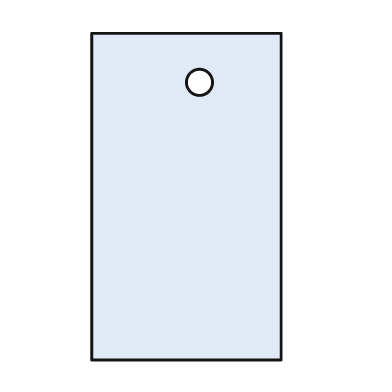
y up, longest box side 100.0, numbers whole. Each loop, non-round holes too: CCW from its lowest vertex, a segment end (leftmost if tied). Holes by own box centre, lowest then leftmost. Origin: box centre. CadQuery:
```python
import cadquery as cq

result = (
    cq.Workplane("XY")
    .moveTo(-29.0, -50.0)
    .lineTo(29.0, -50.0)
    .lineTo(29.0, 50.0)
    .lineTo(-29.0, 50.0)
    .close()
    .moveTo(4.0, 35.0)
    .circle(4.0)
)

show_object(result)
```